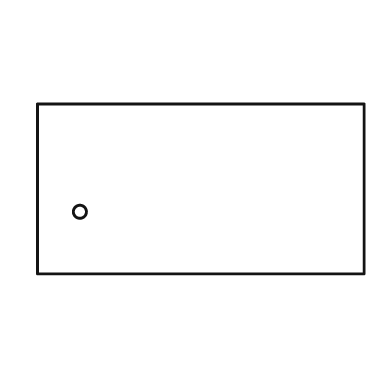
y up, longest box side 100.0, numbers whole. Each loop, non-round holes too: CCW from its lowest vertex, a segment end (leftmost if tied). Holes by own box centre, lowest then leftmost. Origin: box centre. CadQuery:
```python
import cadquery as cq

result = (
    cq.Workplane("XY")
    .moveTo(-50.0, -26.0)
    .lineTo(50.0, -26.0)
    .lineTo(50.0, 26.0)
    .lineTo(-50.0, 26.0)
    .close()
    .moveTo(-37.0, -7.0)
    .circle(2.0)
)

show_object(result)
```